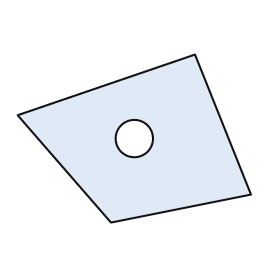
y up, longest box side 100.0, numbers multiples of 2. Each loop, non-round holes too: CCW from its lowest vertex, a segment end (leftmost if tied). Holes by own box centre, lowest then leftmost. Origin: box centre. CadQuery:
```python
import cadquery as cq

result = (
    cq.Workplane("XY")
    .moveTo(-10.0, -36.0)
    .lineTo(50.0, -24.0)
    .lineTo(26.0, 36.0)
    .lineTo(-50.0, 10.0)
    .close()
    .moveTo(0.0, 0.0)
    .circle(8.0)
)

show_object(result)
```